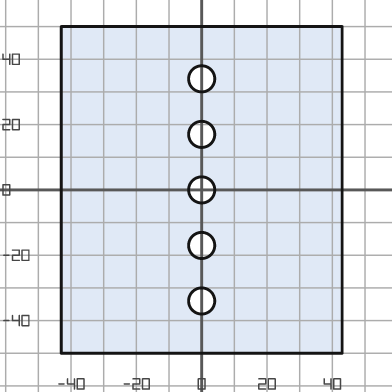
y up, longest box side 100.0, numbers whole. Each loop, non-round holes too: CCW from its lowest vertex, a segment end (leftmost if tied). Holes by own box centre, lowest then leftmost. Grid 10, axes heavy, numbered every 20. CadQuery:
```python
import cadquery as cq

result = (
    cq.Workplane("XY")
    .moveTo(-43.0, -50.0)
    .lineTo(43.0, -50.0)
    .lineTo(43.0, 50.0)
    .lineTo(-43.0, 50.0)
    .close()
    .moveTo(0.0, -34.0)
    .circle(4.0)
    .moveTo(0.0, -17.0)
    .circle(4.0)
    .moveTo(0.0, 0.0)
    .circle(4.0)
    .moveTo(0.0, 17.0)
    .circle(4.0)
    .moveTo(0.0, 34.0)
    .circle(4.0)
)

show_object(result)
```